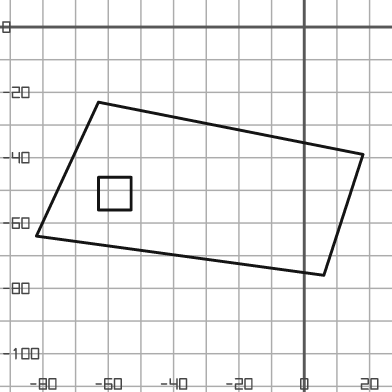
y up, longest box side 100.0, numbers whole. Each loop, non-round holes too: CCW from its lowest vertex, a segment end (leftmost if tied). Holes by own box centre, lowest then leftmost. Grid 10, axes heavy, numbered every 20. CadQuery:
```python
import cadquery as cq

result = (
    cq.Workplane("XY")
    .moveTo(6.0, -76.0)
    .lineTo(18.0, -39.0)
    .lineTo(-63.0, -23.0)
    .lineTo(-82.0, -64.0)
    .close()
    .moveTo(-63.0, -56.0)
    .lineTo(-53.0, -56.0)
    .lineTo(-53.0, -46.0)
    .lineTo(-63.0, -46.0)
    .close()
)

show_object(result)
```